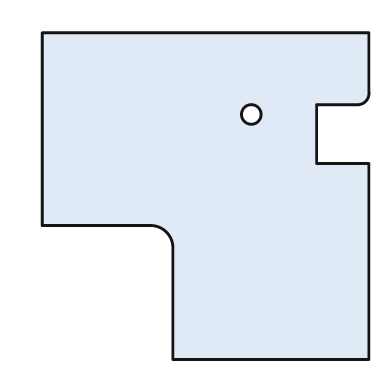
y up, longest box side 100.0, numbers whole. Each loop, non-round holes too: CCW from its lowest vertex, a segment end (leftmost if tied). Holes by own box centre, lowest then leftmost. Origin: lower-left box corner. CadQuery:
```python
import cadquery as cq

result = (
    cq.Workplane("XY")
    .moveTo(40.0, 0.0)
    .lineTo(100.0, 0.0)
    .lineTo(100.0, 60.0)
    .lineTo(84.0, 60.0)
    .lineTo(84.0, 78.0)
    .lineTo(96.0, 78.0)
    .threePointArc((99.0, 79.0), (100.0, 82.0))
    .lineTo(100.0, 100.0)
    .lineTo(0.0, 100.0)
    .lineTo(0.0, 41.0)
    .lineTo(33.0, 41.0)
    .threePointArc((38.0, 39.0), (40.0, 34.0))
    .close()
    .moveTo(64.0, 75.0)
    .circle(3.0)
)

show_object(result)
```